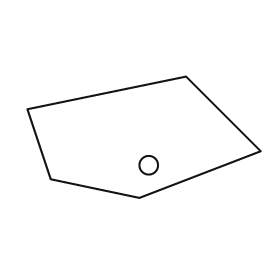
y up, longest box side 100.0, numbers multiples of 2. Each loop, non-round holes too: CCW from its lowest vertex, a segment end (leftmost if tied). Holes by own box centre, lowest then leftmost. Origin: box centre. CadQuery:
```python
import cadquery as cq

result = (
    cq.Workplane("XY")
    .moveTo(-2.0, -26.0)
    .lineTo(50.0, -6.0)
    .lineTo(18.0, 26.0)
    .lineTo(-50.0, 12.0)
    .lineTo(-40.0, -18.0)
    .close()
    .moveTo(2.0, -12.0)
    .circle(4.0)
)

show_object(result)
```